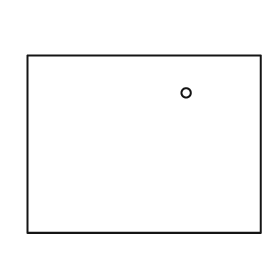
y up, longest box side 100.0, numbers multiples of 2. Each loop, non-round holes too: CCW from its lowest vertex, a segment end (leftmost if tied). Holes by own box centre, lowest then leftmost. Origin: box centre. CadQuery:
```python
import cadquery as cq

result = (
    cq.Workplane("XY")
    .moveTo(-50.0, -38.0)
    .lineTo(50.0, -38.0)
    .lineTo(50.0, 38.0)
    .lineTo(-50.0, 38.0)
    .close()
    .moveTo(18.0, 22.0)
    .circle(2.0)
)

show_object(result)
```